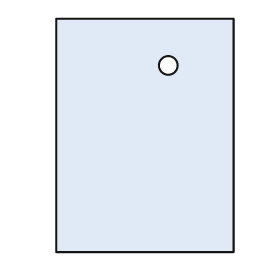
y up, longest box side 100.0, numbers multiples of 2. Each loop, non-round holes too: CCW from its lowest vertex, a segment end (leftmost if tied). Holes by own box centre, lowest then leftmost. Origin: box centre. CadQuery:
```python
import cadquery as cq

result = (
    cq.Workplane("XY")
    .moveTo(-38.0, -50.0)
    .lineTo(38.0, -50.0)
    .lineTo(38.0, 50.0)
    .lineTo(-38.0, 50.0)
    .close()
    .moveTo(10.0, 30.0)
    .circle(4.0)
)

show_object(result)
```